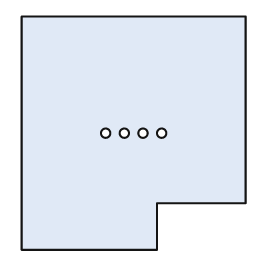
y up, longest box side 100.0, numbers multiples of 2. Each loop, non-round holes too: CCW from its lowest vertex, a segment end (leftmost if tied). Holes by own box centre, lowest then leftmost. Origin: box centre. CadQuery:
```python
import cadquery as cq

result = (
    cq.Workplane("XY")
    .moveTo(-48.0, -50.0)
    .lineTo(10.0, -50.0)
    .lineTo(10.0, -30.0)
    .lineTo(48.0, -30.0)
    .lineTo(48.0, 50.0)
    .lineTo(-48.0, 50.0)
    .close()
    .moveTo(-12.0, 0.0)
    .circle(2.0)
    .moveTo(-4.0, 0.0)
    .circle(2.0)
    .moveTo(4.0, 0.0)
    .circle(2.0)
    .moveTo(12.0, 0.0)
    .circle(2.0)
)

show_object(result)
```